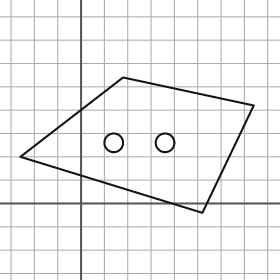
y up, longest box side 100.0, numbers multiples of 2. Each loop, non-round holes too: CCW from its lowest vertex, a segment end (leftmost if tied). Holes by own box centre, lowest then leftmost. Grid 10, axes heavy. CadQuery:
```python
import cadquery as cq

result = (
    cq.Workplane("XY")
    .moveTo(52.0, -4.0)
    .lineTo(74.0, 42.0)
    .lineTo(18.0, 54.0)
    .lineTo(-26.0, 20.0)
    .close()
    .moveTo(14.0, 26.0)
    .circle(4.0)
    .moveTo(36.0, 26.0)
    .circle(4.0)
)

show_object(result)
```